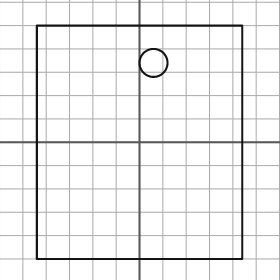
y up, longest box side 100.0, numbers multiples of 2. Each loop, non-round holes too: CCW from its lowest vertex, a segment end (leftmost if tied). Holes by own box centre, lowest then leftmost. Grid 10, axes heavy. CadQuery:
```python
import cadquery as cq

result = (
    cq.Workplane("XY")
    .moveTo(-44.0, -50.0)
    .lineTo(44.0, -50.0)
    .lineTo(44.0, 50.0)
    .lineTo(-44.0, 50.0)
    .close()
    .moveTo(6.0, 34.0)
    .circle(6.0)
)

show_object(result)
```